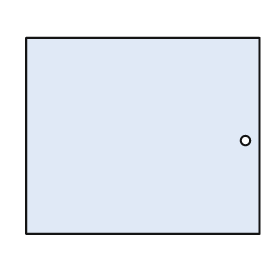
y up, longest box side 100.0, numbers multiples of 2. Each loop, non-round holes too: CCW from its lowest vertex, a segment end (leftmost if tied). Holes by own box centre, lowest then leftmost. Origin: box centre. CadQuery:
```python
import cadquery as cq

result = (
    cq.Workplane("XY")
    .moveTo(-50.0, -42.0)
    .lineTo(50.0, -42.0)
    .lineTo(50.0, 42.0)
    .lineTo(-50.0, 42.0)
    .close()
    .moveTo(44.0, -2.0)
    .circle(2.0)
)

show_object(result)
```